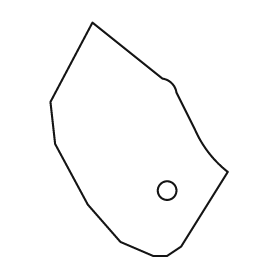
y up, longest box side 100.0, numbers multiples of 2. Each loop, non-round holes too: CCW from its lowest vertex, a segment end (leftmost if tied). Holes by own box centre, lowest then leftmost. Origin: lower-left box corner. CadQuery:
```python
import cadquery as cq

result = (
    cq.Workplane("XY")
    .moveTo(44.0, 0.0)
    .lineTo(50.0, 0.0)
    .lineTo(56.0, 4.0)
    .lineTo(76.0, 36.0)
    .threePointArc((68.0, 44.0), (62.0, 54.0))
    .lineTo(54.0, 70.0)
    .threePointArc((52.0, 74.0), (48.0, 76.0))
    .lineTo(18.0, 100.0)
    .lineTo(0.0, 66.0)
    .lineTo(2.0, 48.0)
    .lineTo(16.0, 22.0)
    .lineTo(30.0, 6.0)
    .close()
    .moveTo(50.0, 28.0)
    .circle(4.0)
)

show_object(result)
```